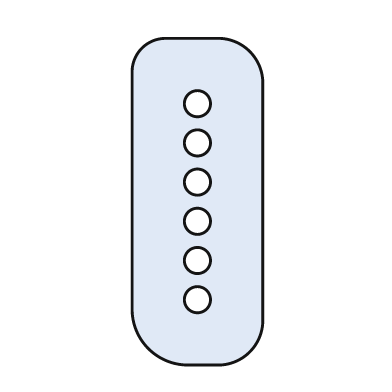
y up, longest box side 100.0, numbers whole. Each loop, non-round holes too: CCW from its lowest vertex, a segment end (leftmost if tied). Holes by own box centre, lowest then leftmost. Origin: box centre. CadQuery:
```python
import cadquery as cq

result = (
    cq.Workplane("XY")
    .moveTo(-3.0, -50.0)
    .lineTo(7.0, -50.0)
    .threePointArc((16.0, -46.0), (20.0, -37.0))
    .lineTo(20.0, 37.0)
    .threePointArc((16.0, 46.0), (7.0, 50.0))
    .lineTo(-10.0, 50.0)
    .threePointArc((-17.0, 47.0), (-20.0, 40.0))
    .lineTo(-20.0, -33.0)
    .threePointArc((-15.0, -45.0), (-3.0, -50.0))
    .close()
    .moveTo(0.0, -30.0)
    .circle(4.0)
    .moveTo(0.0, -18.0)
    .circle(4.0)
    .moveTo(0.0, -6.0)
    .circle(4.0)
    .moveTo(0.0, 6.0)
    .circle(4.0)
    .moveTo(0.0, 18.0)
    .circle(4.0)
    .moveTo(0.0, 30.0)
    .circle(4.0)
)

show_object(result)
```